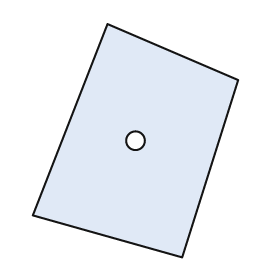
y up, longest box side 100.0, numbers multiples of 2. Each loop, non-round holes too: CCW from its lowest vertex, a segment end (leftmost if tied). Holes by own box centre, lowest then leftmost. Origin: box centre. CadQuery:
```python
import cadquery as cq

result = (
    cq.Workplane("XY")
    .moveTo(20.0, -50.0)
    .lineTo(44.0, 26.0)
    .lineTo(-12.0, 50.0)
    .lineTo(-44.0, -32.0)
    .close()
    .moveTo(0.0, 0.0)
    .circle(4.0)
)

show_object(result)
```